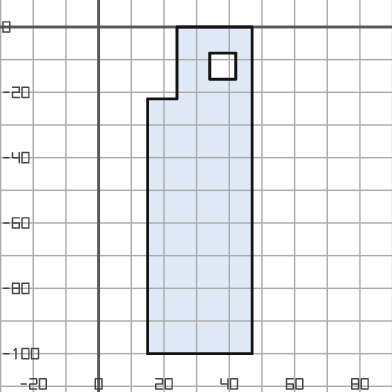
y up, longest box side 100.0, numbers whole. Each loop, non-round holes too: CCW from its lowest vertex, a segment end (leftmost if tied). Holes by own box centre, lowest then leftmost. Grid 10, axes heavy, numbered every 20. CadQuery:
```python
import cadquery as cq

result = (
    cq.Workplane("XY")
    .moveTo(15.0, -100.0)
    .lineTo(47.0, -100.0)
    .lineTo(47.0, 0.0)
    .lineTo(24.0, 0.0)
    .lineTo(24.0, -22.0)
    .lineTo(15.0, -22.0)
    .close()
    .moveTo(34.0, -16.0)
    .lineTo(42.0, -16.0)
    .lineTo(42.0, -8.0)
    .lineTo(34.0, -8.0)
    .close()
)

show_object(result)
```